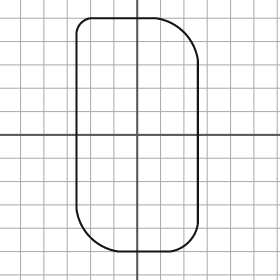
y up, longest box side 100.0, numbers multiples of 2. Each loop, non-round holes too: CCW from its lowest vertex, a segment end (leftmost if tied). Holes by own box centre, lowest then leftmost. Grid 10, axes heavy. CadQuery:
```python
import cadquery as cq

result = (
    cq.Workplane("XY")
    .moveTo(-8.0, -50.0)
    .lineTo(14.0, -50.0)
    .threePointArc((22.0, -46.0), (26.0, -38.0))
    .lineTo(26.0, 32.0)
    .threePointArc((20.0, 44.0), (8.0, 50.0))
    .lineTo(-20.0, 50.0)
    .threePointArc((-24.0, 48.0), (-26.0, 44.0))
    .lineTo(-26.0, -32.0)
    .threePointArc((-20.0, -44.0), (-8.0, -50.0))
    .close()
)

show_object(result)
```